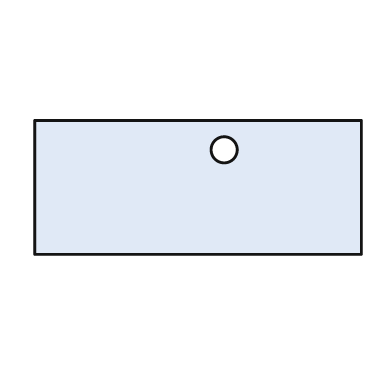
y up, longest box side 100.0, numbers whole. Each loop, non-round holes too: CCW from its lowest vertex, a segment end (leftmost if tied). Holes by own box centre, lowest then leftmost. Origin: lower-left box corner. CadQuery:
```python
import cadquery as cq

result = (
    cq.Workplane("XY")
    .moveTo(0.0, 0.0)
    .lineTo(100.0, 0.0)
    .lineTo(100.0, 41.0)
    .lineTo(0.0, 41.0)
    .close()
    .moveTo(58.0, 32.0)
    .circle(4.0)
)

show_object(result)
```